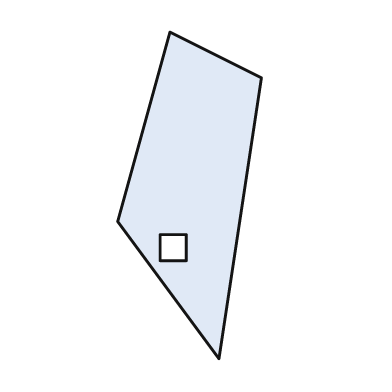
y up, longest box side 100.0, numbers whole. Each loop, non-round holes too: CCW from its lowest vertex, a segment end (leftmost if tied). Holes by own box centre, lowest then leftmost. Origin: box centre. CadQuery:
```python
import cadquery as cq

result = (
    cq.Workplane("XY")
    .moveTo(9.0, -50.0)
    .lineTo(22.0, 36.0)
    .lineTo(-6.0, 50.0)
    .lineTo(-22.0, -8.0)
    .close()
    .moveTo(-9.0, -20.0)
    .lineTo(-1.0, -20.0)
    .lineTo(-1.0, -12.0)
    .lineTo(-9.0, -12.0)
    .close()
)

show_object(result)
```